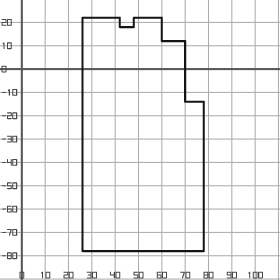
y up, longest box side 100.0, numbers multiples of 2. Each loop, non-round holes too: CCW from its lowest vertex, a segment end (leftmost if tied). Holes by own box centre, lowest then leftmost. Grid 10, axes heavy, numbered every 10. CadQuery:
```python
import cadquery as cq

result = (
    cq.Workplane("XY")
    .moveTo(26.0, -78.0)
    .lineTo(78.0, -78.0)
    .lineTo(78.0, -14.0)
    .lineTo(70.0, -14.0)
    .lineTo(70.0, 12.0)
    .lineTo(60.0, 12.0)
    .lineTo(60.0, 22.0)
    .lineTo(48.0, 22.0)
    .lineTo(48.0, 18.0)
    .lineTo(42.0, 18.0)
    .lineTo(42.0, 22.0)
    .lineTo(26.0, 22.0)
    .close()
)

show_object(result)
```